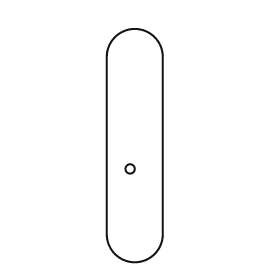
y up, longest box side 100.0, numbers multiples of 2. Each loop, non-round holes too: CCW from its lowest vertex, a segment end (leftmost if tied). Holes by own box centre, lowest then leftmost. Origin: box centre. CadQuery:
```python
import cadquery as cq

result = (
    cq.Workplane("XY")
    .moveTo(-12.0, -38.0)
    .threePointArc((0.0, -50.0), (12.0, -38.0))
    .lineTo(12.0, 38.0)
    .threePointArc((0.0, 50.0), (-12.0, 38.0))
    .close()
    .moveTo(-2.0, -10.0)
    .circle(2.0)
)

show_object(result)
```